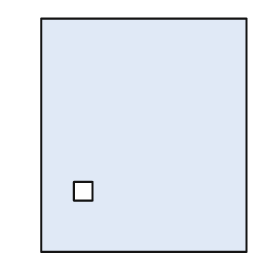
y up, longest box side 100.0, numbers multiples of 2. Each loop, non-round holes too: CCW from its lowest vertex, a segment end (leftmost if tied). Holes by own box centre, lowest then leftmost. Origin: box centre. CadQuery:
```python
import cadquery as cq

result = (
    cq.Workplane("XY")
    .moveTo(-44.0, -50.0)
    .lineTo(44.0, -50.0)
    .lineTo(44.0, 50.0)
    .lineTo(-44.0, 50.0)
    .close()
    .moveTo(-30.0, -28.0)
    .lineTo(-22.0, -28.0)
    .lineTo(-22.0, -20.0)
    .lineTo(-30.0, -20.0)
    .close()
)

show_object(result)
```